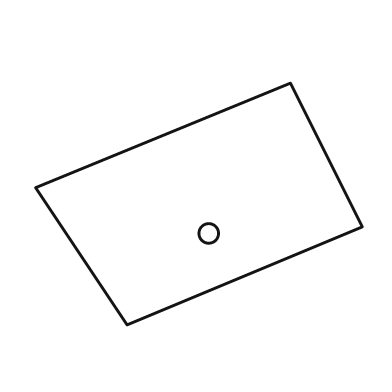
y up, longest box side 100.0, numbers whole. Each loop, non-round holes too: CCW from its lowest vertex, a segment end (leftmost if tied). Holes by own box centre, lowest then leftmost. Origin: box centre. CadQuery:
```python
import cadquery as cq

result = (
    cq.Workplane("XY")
    .moveTo(-22.0, -37.0)
    .lineTo(50.0, -7.0)
    .lineTo(28.0, 37.0)
    .lineTo(-50.0, 5.0)
    .close()
    .moveTo(3.0, -9.0)
    .circle(3.0)
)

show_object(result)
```